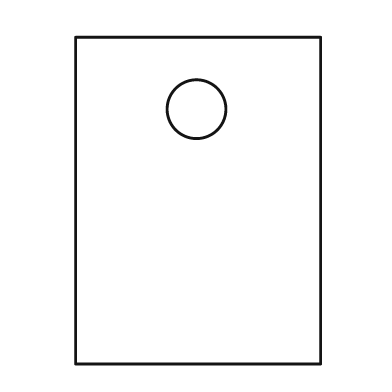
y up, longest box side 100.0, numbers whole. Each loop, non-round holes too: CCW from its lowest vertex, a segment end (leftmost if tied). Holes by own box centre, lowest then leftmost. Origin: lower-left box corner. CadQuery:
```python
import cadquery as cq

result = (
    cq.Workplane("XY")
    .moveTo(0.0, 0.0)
    .lineTo(75.0, 0.0)
    .lineTo(75.0, 100.0)
    .lineTo(0.0, 100.0)
    .close()
    .moveTo(37.0, 78.0)
    .circle(9.0)
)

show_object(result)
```